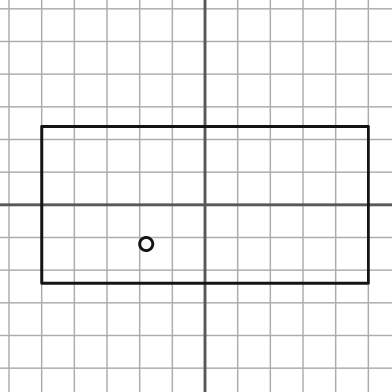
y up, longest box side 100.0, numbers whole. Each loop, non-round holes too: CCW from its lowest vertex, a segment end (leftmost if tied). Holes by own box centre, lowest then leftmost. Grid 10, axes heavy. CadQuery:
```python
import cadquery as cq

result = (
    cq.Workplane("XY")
    .moveTo(-50.0, -24.0)
    .lineTo(50.0, -24.0)
    .lineTo(50.0, 24.0)
    .lineTo(-50.0, 24.0)
    .close()
    .moveTo(-18.0, -12.0)
    .circle(2.0)
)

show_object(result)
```